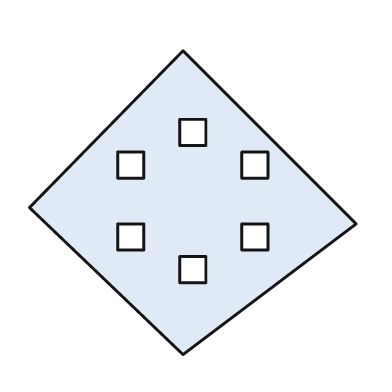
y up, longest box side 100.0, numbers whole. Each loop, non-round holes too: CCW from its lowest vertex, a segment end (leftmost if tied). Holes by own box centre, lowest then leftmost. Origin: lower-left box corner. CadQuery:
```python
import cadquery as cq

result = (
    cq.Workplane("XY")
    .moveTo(47.0, 0.0)
    .lineTo(100.0, 40.0)
    .lineTo(47.0, 93.0)
    .lineTo(0.0, 45.0)
    .close()
    .moveTo(46.0, 22.0)
    .lineTo(54.0, 22.0)
    .lineTo(54.0, 30.0)
    .lineTo(46.0, 30.0)
    .close()
    .moveTo(27.0, 32.0)
    .lineTo(35.0, 32.0)
    .lineTo(35.0, 40.0)
    .lineTo(27.0, 40.0)
    .close()
    .moveTo(65.0, 32.0)
    .lineTo(73.0, 32.0)
    .lineTo(73.0, 40.0)
    .lineTo(65.0, 40.0)
    .close()
    .moveTo(27.0, 54.0)
    .lineTo(35.0, 54.0)
    .lineTo(35.0, 62.0)
    .lineTo(27.0, 62.0)
    .close()
    .moveTo(65.0, 54.0)
    .lineTo(73.0, 54.0)
    .lineTo(73.0, 62.0)
    .lineTo(65.0, 62.0)
    .close()
    .moveTo(46.0, 64.0)
    .lineTo(54.0, 64.0)
    .lineTo(54.0, 72.0)
    .lineTo(46.0, 72.0)
    .close()
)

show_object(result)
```